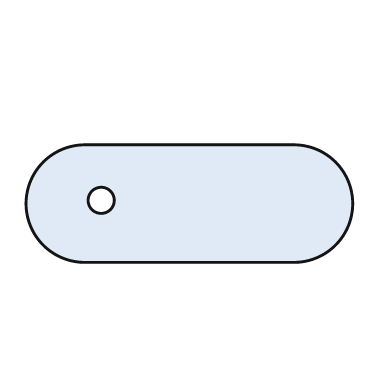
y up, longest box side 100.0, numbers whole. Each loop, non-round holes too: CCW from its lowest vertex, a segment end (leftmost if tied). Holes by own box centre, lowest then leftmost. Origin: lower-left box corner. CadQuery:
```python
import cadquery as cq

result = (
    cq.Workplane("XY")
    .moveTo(18.0, 0.0)
    .lineTo(82.0, 0.0)
    .threePointArc((100.0, 18.0), (82.0, 36.0))
    .lineTo(18.0, 36.0)
    .threePointArc((0.0, 18.0), (18.0, 0.0))
    .close()
    .moveTo(23.0, 19.0)
    .circle(4.0)
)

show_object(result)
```